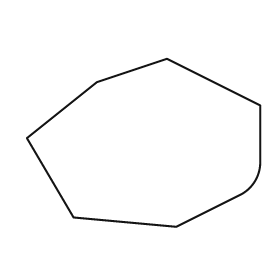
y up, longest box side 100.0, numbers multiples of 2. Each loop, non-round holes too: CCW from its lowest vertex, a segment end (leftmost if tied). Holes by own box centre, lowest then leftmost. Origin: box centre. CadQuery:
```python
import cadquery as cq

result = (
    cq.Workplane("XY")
    .moveTo(14.0, -36.0)
    .lineTo(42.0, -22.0)
    .threePointArc((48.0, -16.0), (50.0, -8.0))
    .lineTo(50.0, 16.0)
    .lineTo(10.0, 36.0)
    .lineTo(-20.0, 26.0)
    .lineTo(-50.0, 2.0)
    .lineTo(-30.0, -32.0)
    .close()
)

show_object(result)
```